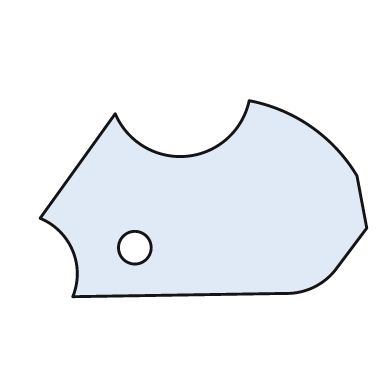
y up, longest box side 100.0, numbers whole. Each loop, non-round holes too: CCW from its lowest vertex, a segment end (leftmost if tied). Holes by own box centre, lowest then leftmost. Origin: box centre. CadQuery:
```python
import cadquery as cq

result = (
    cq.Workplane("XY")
    .moveTo(-40.0, -30.0)
    .lineTo(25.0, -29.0)
    .threePointArc((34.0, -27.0), (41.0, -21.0))
    .lineTo(50.0, -9.0)
    .lineTo(47.0, 7.0)
    .threePointArc((33.0, 22.0), (14.0, 30.0))
    .threePointArc((-5.0, 13.0), (-27.0, 26.0))
    .lineTo(-50.0, -6.0)
    .threePointArc((-40.0, -16.0), (-40.0, -30.0))
    .close()
    .moveTo(-21.0, -15.0)
    .circle(5.0)
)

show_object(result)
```